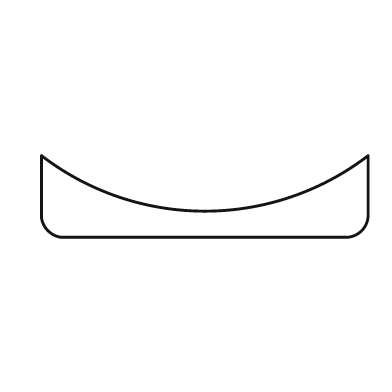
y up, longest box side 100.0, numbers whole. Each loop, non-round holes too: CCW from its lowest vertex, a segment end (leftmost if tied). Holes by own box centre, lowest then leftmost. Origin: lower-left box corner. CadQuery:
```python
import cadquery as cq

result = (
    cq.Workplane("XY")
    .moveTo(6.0, 0.0)
    .lineTo(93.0, 0.0)
    .threePointArc((98.0, 2.0), (100.0, 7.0))
    .lineTo(100.0, 25.0)
    .threePointArc((50.0, 8.0), (0.0, 25.0))
    .lineTo(0.0, 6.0)
    .threePointArc((2.0, 2.0), (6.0, 0.0))
    .close()
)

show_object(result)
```